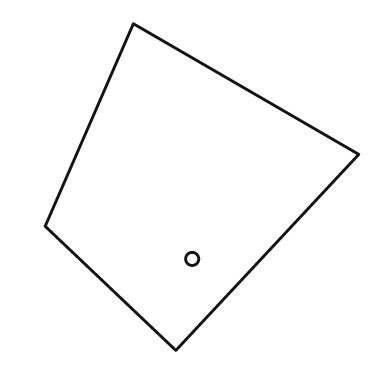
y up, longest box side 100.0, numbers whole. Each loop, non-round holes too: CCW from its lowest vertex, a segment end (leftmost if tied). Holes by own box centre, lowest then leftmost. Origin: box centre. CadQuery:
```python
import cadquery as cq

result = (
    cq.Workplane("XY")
    .moveTo(-8.0, -50.0)
    .lineTo(48.0, 10.0)
    .lineTo(-21.0, 50.0)
    .lineTo(-48.0, -12.0)
    .close()
    .moveTo(-3.0, -22.0)
    .circle(2.0)
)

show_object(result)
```